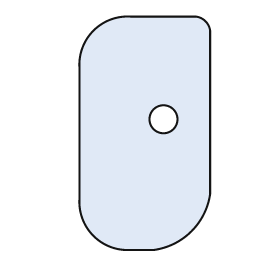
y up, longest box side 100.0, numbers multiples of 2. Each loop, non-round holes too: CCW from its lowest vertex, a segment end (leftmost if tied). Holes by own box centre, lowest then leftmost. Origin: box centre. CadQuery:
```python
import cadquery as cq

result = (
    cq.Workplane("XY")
    .moveTo(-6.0, -50.0)
    .lineTo(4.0, -50.0)
    .threePointArc((20.0, -42.0), (28.0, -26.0))
    .lineTo(28.0, 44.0)
    .threePointArc((26.0, 48.0), (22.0, 50.0))
    .lineTo(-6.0, 50.0)
    .threePointArc((-22.0, 44.0), (-28.0, 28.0))
    .lineTo(-28.0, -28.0)
    .threePointArc((-22.0, -44.0), (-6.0, -50.0))
    .close()
    .moveTo(8.0, 6.0)
    .circle(6.0)
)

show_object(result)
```